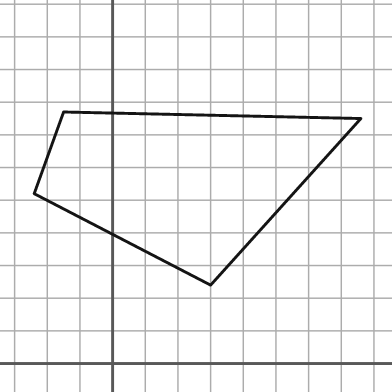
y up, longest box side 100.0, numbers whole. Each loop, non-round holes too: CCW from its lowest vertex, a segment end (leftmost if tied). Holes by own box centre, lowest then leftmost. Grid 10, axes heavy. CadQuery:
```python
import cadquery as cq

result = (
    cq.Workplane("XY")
    .moveTo(30.0, 24.0)
    .lineTo(76.0, 75.0)
    .lineTo(-15.0, 77.0)
    .lineTo(-24.0, 52.0)
    .close()
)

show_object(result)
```